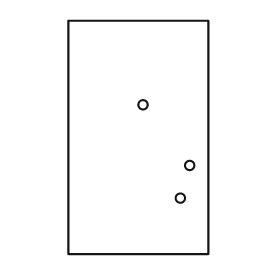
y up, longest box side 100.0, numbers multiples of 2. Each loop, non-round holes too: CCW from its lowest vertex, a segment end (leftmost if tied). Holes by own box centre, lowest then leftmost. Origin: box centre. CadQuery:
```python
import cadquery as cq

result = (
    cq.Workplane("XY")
    .moveTo(-30.0, -50.0)
    .lineTo(30.0, -50.0)
    .lineTo(30.0, 50.0)
    .lineTo(-30.0, 50.0)
    .close()
    .moveTo(18.0, -26.0)
    .circle(2.0)
    .moveTo(22.0, -12.0)
    .circle(2.0)
    .moveTo(2.0, 14.0)
    .circle(2.0)
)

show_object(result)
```